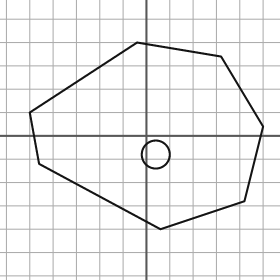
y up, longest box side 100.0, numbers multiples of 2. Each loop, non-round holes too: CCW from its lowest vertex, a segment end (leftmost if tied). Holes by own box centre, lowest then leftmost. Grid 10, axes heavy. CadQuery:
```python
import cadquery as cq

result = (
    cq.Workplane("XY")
    .moveTo(6.0, -40.0)
    .lineTo(42.0, -28.0)
    .lineTo(50.0, 4.0)
    .lineTo(32.0, 34.0)
    .lineTo(-4.0, 40.0)
    .lineTo(-50.0, 10.0)
    .lineTo(-46.0, -12.0)
    .close()
    .moveTo(4.0, -8.0)
    .circle(6.0)
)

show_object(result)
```